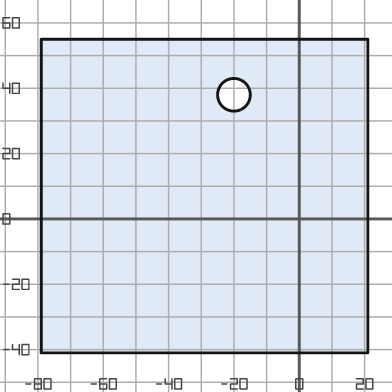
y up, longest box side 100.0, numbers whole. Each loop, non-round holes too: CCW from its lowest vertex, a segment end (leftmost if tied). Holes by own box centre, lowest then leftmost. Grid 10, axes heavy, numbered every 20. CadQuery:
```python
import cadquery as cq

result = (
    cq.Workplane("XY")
    .moveTo(-79.0, -41.0)
    .lineTo(21.0, -41.0)
    .lineTo(21.0, 55.0)
    .lineTo(-79.0, 55.0)
    .close()
    .moveTo(-20.0, 38.0)
    .circle(5.0)
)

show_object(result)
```